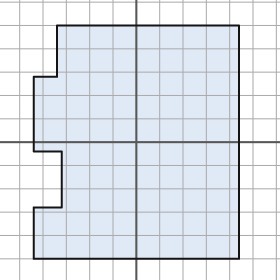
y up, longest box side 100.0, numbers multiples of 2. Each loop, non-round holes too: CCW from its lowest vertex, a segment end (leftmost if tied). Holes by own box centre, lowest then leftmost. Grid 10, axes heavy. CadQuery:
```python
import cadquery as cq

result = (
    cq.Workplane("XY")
    .moveTo(-44.0, -50.0)
    .lineTo(44.0, -50.0)
    .lineTo(44.0, 50.0)
    .lineTo(-34.0, 50.0)
    .lineTo(-34.0, 28.0)
    .lineTo(-44.0, 28.0)
    .lineTo(-44.0, -4.0)
    .lineTo(-32.0, -4.0)
    .lineTo(-32.0, -28.0)
    .lineTo(-44.0, -28.0)
    .close()
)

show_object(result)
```